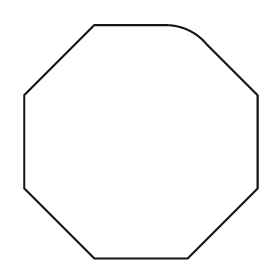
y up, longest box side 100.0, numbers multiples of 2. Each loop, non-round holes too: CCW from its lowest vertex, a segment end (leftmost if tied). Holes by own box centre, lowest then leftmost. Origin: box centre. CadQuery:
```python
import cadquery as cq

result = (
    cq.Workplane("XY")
    .moveTo(-20.0, -50.0)
    .lineTo(20.0, -50.0)
    .lineTo(50.0, -20.0)
    .lineTo(50.0, 20.0)
    .lineTo(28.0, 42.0)
    .threePointArc((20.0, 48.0), (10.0, 50.0))
    .lineTo(-20.0, 50.0)
    .lineTo(-50.0, 20.0)
    .lineTo(-50.0, -20.0)
    .close()
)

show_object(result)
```